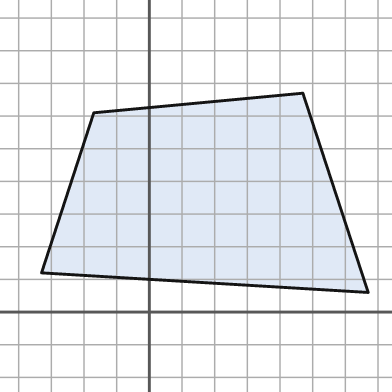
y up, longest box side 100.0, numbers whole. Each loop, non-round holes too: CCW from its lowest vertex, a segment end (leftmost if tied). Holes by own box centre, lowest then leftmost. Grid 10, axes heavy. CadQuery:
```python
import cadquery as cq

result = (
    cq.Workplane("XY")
    .moveTo(67.0, 6.0)
    .lineTo(47.0, 67.0)
    .lineTo(-17.0, 61.0)
    .lineTo(-33.0, 12.0)
    .close()
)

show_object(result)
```